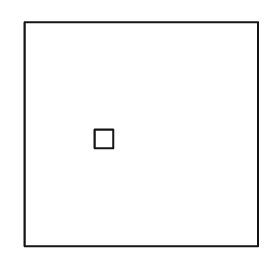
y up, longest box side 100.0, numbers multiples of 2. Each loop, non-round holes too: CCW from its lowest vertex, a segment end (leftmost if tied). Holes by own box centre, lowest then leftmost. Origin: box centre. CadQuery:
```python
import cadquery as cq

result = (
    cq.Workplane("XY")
    .moveTo(-50.0, -48.0)
    .lineTo(50.0, -48.0)
    .lineTo(50.0, 48.0)
    .lineTo(-50.0, 48.0)
    .close()
    .moveTo(-20.0, -6.0)
    .lineTo(-12.0, -6.0)
    .lineTo(-12.0, 2.0)
    .lineTo(-20.0, 2.0)
    .close()
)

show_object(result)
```